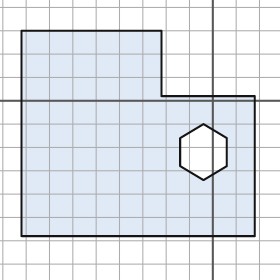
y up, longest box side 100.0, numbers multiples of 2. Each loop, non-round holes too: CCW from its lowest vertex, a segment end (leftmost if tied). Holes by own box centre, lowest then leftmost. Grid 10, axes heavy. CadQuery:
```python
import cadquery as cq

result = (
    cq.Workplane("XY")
    .moveTo(-82.0, -58.0)
    .lineTo(18.0, -58.0)
    .lineTo(18.0, 2.0)
    .lineTo(-22.0, 2.0)
    .lineTo(-22.0, 30.0)
    .lineTo(-82.0, 30.0)
    .close()
    .moveTo(-4.0, -34.0)
    .lineTo(6.0, -28.0)
    .lineTo(6.0, -16.0)
    .lineTo(-4.0, -10.0)
    .lineTo(-14.0, -16.0)
    .lineTo(-14.0, -28.0)
    .close()
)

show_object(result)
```